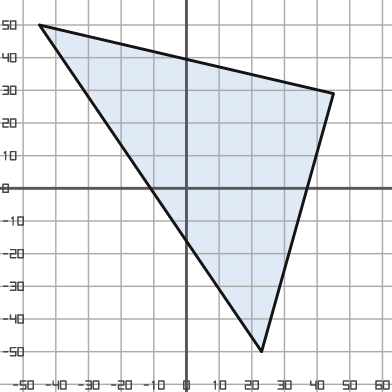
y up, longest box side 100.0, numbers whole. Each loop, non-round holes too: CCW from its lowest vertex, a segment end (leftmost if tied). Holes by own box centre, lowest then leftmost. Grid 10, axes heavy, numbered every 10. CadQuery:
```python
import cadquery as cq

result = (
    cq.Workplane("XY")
    .moveTo(23.0, -50.0)
    .lineTo(45.0, 29.0)
    .lineTo(-45.0, 50.0)
    .close()
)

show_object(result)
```